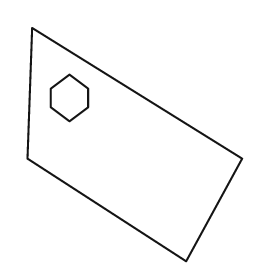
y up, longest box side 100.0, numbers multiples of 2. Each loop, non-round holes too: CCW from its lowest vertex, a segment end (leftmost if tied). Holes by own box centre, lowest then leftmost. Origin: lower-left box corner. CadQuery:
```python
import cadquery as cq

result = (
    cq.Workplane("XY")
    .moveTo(68.0, 0.0)
    .lineTo(92.0, 44.0)
    .lineTo(2.0, 100.0)
    .lineTo(0.0, 44.0)
    .close()
    .moveTo(18.0, 60.0)
    .lineTo(26.0, 66.0)
    .lineTo(26.0, 74.0)
    .lineTo(18.0, 80.0)
    .lineTo(10.0, 74.0)
    .lineTo(10.0, 66.0)
    .close()
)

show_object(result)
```